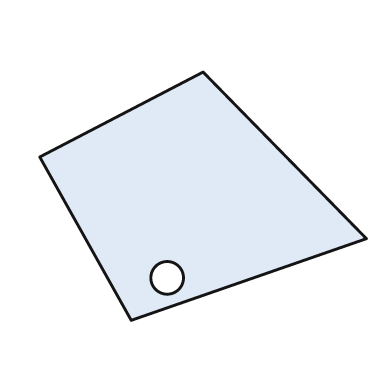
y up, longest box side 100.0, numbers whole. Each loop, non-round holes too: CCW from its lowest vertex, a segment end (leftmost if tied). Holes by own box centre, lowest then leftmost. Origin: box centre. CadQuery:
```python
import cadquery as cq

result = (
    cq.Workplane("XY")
    .moveTo(-22.0, -38.0)
    .lineTo(50.0, -13.0)
    .lineTo(0.0, 38.0)
    .lineTo(-50.0, 12.0)
    .close()
    .moveTo(-11.0, -25.0)
    .circle(5.0)
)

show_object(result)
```